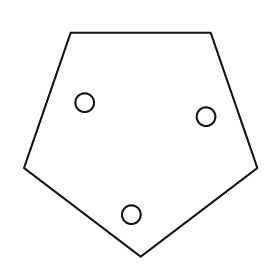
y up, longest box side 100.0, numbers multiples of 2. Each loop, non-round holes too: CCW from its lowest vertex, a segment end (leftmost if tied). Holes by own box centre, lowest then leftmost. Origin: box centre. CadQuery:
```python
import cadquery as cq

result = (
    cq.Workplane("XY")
    .moveTo(0.0, -48.0)
    .lineTo(50.0, -10.0)
    .lineTo(30.0, 48.0)
    .lineTo(-30.0, 48.0)
    .lineTo(-50.0, -10.0)
    .close()
    .moveTo(-4.0, -30.0)
    .circle(4.0)
    .moveTo(28.0, 12.0)
    .circle(4.0)
    .moveTo(-24.0, 18.0)
    .circle(4.0)
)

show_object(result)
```